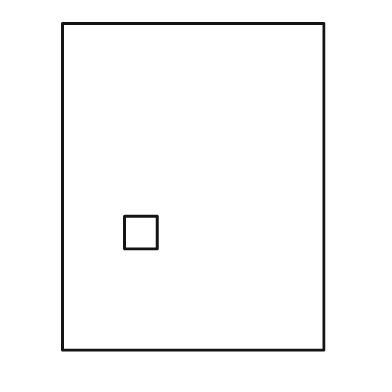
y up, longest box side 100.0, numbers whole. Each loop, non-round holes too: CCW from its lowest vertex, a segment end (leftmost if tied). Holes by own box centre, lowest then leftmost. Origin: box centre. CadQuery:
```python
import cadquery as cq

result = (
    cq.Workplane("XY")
    .moveTo(-40.0, -50.0)
    .lineTo(40.0, -50.0)
    .lineTo(40.0, 50.0)
    .lineTo(-40.0, 50.0)
    .close()
    .moveTo(-21.0, -19.0)
    .lineTo(-11.0, -19.0)
    .lineTo(-11.0, -9.0)
    .lineTo(-21.0, -9.0)
    .close()
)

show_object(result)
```